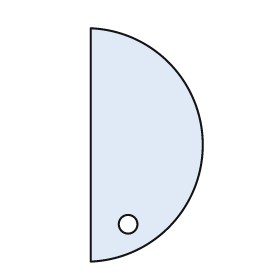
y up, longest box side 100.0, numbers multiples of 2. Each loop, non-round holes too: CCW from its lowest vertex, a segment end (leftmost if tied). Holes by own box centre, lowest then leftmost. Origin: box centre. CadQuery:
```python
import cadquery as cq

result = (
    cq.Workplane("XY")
    .moveTo(-24.0, -50.0)
    .threePointArc((24.0, 0.0), (-24.0, 50.0))
    .close()
    .moveTo(-8.0, -34.0)
    .circle(4.0)
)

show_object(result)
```